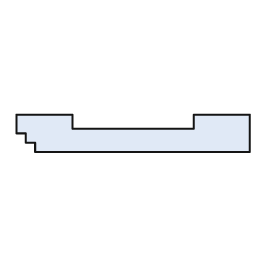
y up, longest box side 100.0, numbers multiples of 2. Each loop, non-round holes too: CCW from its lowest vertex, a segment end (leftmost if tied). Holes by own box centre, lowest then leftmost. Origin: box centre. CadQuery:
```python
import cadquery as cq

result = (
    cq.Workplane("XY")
    .moveTo(-42.0, -8.0)
    .lineTo(50.0, -8.0)
    .lineTo(50.0, 8.0)
    .lineTo(26.0, 8.0)
    .lineTo(26.0, 2.0)
    .lineTo(-26.0, 2.0)
    .lineTo(-26.0, 8.0)
    .lineTo(-50.0, 8.0)
    .lineTo(-50.0, 0.0)
    .lineTo(-46.0, 0.0)
    .lineTo(-46.0, -4.0)
    .lineTo(-42.0, -4.0)
    .close()
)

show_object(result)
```